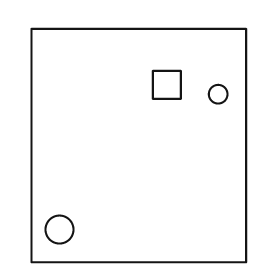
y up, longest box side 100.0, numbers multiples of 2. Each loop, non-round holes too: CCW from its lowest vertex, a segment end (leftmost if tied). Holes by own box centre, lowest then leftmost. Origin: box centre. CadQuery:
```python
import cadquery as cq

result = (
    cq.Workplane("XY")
    .moveTo(-46.0, -50.0)
    .lineTo(46.0, -50.0)
    .lineTo(46.0, 50.0)
    .lineTo(-46.0, 50.0)
    .close()
    .moveTo(-34.0, -36.0)
    .circle(6.0)
    .moveTo(34.0, 22.0)
    .circle(4.0)
    .moveTo(6.0, 20.0)
    .lineTo(18.0, 20.0)
    .lineTo(18.0, 32.0)
    .lineTo(6.0, 32.0)
    .close()
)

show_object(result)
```